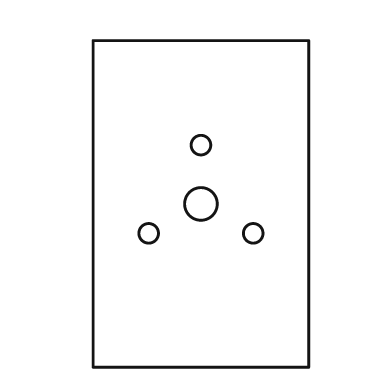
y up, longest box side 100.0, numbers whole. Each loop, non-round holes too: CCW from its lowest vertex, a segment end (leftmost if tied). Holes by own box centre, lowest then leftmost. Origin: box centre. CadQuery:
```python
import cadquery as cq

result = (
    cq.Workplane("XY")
    .moveTo(-33.0, -50.0)
    .lineTo(33.0, -50.0)
    .lineTo(33.0, 50.0)
    .lineTo(-33.0, 50.0)
    .close()
    .moveTo(-16.0, -9.0)
    .circle(3.0)
    .moveTo(16.0, -9.0)
    .circle(3.0)
    .moveTo(0.0, 0.0)
    .circle(5.0)
    .moveTo(0.0, 18.0)
    .circle(3.0)
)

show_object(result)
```